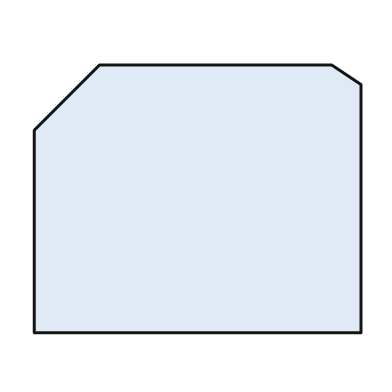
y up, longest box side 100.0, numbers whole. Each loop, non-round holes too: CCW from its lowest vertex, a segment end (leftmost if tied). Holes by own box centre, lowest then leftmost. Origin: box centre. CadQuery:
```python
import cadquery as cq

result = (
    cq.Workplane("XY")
    .moveTo(-50.0, -41.0)
    .lineTo(50.0, -41.0)
    .lineTo(50.0, 35.0)
    .lineTo(41.0, 41.0)
    .lineTo(-30.0, 41.0)
    .lineTo(-50.0, 21.0)
    .close()
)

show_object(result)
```